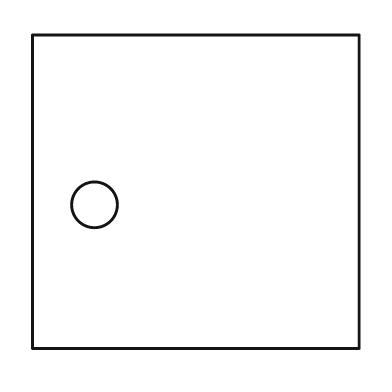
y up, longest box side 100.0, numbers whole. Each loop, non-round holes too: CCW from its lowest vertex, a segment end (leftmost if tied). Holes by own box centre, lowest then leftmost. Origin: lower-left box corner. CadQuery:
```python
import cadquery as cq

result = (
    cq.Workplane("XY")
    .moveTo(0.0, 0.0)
    .lineTo(100.0, 0.0)
    .lineTo(100.0, 96.0)
    .lineTo(0.0, 96.0)
    .close()
    .moveTo(19.0, 44.0)
    .circle(7.0)
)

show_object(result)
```